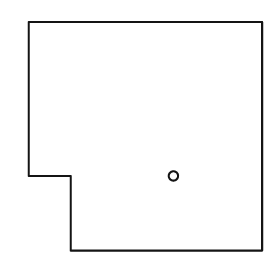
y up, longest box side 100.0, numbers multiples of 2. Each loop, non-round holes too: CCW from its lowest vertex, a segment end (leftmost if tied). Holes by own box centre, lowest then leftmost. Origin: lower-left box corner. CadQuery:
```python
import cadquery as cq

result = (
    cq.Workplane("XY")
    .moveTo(18.0, 0.0)
    .lineTo(100.0, 0.0)
    .lineTo(100.0, 98.0)
    .lineTo(0.0, 98.0)
    .lineTo(0.0, 32.0)
    .lineTo(18.0, 32.0)
    .close()
    .moveTo(62.0, 32.0)
    .circle(2.0)
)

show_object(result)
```